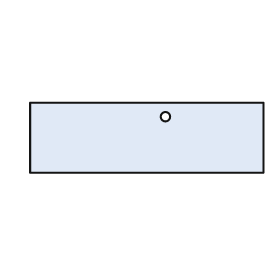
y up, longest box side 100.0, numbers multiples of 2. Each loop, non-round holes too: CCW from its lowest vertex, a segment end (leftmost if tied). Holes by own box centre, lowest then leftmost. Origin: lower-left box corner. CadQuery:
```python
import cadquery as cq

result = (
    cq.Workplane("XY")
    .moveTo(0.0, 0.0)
    .lineTo(100.0, 0.0)
    .lineTo(100.0, 30.0)
    .lineTo(0.0, 30.0)
    .close()
    .moveTo(58.0, 24.0)
    .circle(2.0)
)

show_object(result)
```